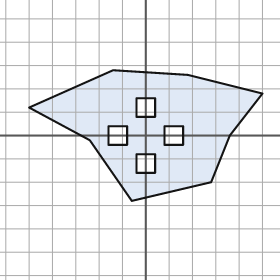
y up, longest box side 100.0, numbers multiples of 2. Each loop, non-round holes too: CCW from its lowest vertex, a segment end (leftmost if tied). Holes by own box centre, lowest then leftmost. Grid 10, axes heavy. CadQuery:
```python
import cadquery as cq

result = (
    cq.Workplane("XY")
    .moveTo(-6.0, -28.0)
    .lineTo(28.0, -20.0)
    .lineTo(36.0, 0.0)
    .lineTo(50.0, 18.0)
    .lineTo(18.0, 26.0)
    .lineTo(-14.0, 28.0)
    .lineTo(-50.0, 12.0)
    .lineTo(-24.0, -2.0)
    .close()
    .moveTo(-4.0, -16.0)
    .lineTo(4.0, -16.0)
    .lineTo(4.0, -8.0)
    .lineTo(-4.0, -8.0)
    .close()
    .moveTo(-16.0, -4.0)
    .lineTo(-8.0, -4.0)
    .lineTo(-8.0, 4.0)
    .lineTo(-16.0, 4.0)
    .close()
    .moveTo(8.0, -4.0)
    .lineTo(16.0, -4.0)
    .lineTo(16.0, 4.0)
    .lineTo(8.0, 4.0)
    .close()
    .moveTo(-4.0, 8.0)
    .lineTo(4.0, 8.0)
    .lineTo(4.0, 16.0)
    .lineTo(-4.0, 16.0)
    .close()
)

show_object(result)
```